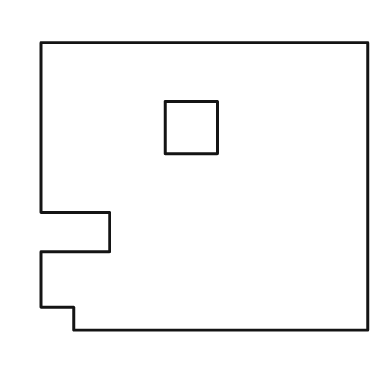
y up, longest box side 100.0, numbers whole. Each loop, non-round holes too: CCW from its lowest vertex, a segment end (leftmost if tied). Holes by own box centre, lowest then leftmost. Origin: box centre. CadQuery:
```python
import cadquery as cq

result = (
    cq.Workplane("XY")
    .moveTo(-40.0, -44.0)
    .lineTo(50.0, -44.0)
    .lineTo(50.0, 44.0)
    .lineTo(-50.0, 44.0)
    .lineTo(-50.0, -8.0)
    .lineTo(-29.0, -8.0)
    .lineTo(-29.0, -20.0)
    .lineTo(-50.0, -20.0)
    .lineTo(-50.0, -37.0)
    .lineTo(-40.0, -37.0)
    .close()
    .moveTo(-12.0, 10.0)
    .lineTo(4.0, 10.0)
    .lineTo(4.0, 26.0)
    .lineTo(-12.0, 26.0)
    .close()
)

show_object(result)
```